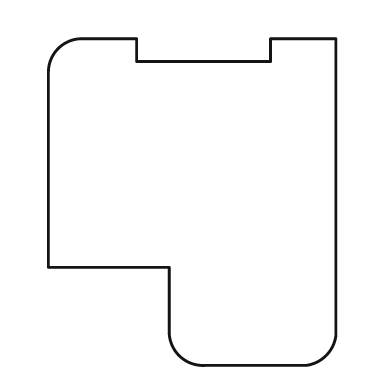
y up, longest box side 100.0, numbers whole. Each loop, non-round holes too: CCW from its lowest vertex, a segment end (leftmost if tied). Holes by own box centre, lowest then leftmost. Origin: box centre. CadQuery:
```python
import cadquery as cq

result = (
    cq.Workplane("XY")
    .moveTo(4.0, -50.0)
    .lineTo(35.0, -50.0)
    .threePointArc((41.0, -47.0), (44.0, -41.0))
    .lineTo(44.0, 50.0)
    .lineTo(24.0, 50.0)
    .lineTo(24.0, 43.0)
    .lineTo(-17.0, 43.0)
    .lineTo(-17.0, 50.0)
    .lineTo(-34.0, 50.0)
    .threePointArc((-41.0, 47.0), (-44.0, 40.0))
    .lineTo(-44.0, -20.0)
    .lineTo(-7.0, -20.0)
    .lineTo(-7.0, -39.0)
    .threePointArc((-4.0, -47.0), (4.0, -50.0))
    .close()
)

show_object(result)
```